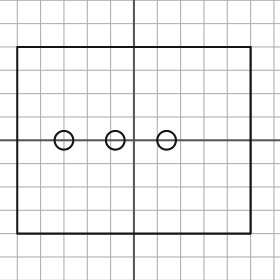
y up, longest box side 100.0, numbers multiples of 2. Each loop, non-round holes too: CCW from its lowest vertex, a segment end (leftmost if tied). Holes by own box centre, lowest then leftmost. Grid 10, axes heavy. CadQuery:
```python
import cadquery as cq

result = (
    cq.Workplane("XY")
    .moveTo(-50.0, -40.0)
    .lineTo(50.0, -40.0)
    .lineTo(50.0, 40.0)
    .lineTo(-50.0, 40.0)
    .close()
    .moveTo(-30.0, 0.0)
    .circle(4.0)
    .moveTo(-8.0, 0.0)
    .circle(4.0)
    .moveTo(14.0, 0.0)
    .circle(4.0)
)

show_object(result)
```